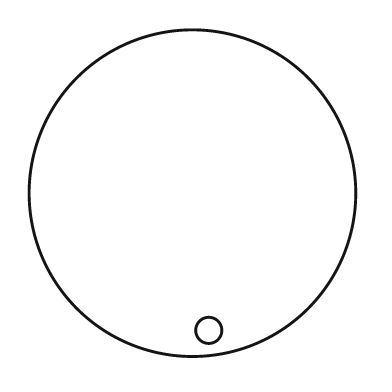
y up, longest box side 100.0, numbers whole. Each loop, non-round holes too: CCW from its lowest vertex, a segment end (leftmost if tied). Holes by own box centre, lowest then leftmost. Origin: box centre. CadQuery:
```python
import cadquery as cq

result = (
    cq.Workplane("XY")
    .moveTo(0.0, 0.0)
    .circle(50.0)
    .moveTo(5.0, -42.0)
    .circle(4.0)
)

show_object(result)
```